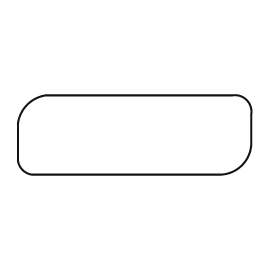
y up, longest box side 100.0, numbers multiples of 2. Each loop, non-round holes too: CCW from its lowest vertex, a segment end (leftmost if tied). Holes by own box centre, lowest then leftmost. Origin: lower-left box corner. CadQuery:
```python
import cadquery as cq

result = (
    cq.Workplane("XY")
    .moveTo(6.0, 0.0)
    .lineTo(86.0, 0.0)
    .threePointArc((96.0, 4.0), (100.0, 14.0))
    .lineTo(100.0, 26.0)
    .threePointArc((98.0, 32.0), (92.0, 34.0))
    .lineTo(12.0, 34.0)
    .threePointArc((4.0, 30.0), (0.0, 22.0))
    .lineTo(0.0, 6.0)
    .threePointArc((2.0, 2.0), (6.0, 0.0))
    .close()
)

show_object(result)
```